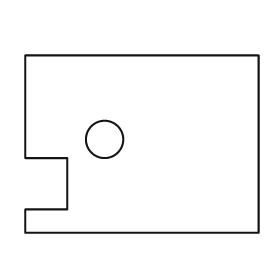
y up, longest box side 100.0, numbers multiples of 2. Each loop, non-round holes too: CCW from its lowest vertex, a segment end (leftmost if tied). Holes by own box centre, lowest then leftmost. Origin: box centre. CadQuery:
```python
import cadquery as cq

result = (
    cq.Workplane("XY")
    .moveTo(-50.0, -38.0)
    .lineTo(50.0, -38.0)
    .lineTo(50.0, 38.0)
    .lineTo(-50.0, 38.0)
    .lineTo(-50.0, -6.0)
    .lineTo(-32.0, -6.0)
    .lineTo(-32.0, -28.0)
    .lineTo(-50.0, -28.0)
    .close()
    .moveTo(-16.0, 2.0)
    .circle(8.0)
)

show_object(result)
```